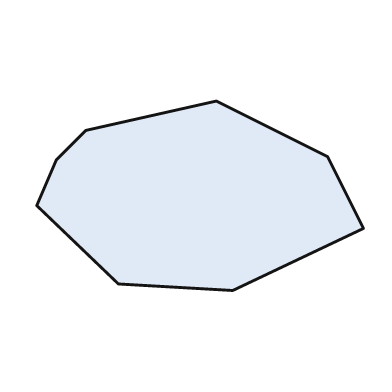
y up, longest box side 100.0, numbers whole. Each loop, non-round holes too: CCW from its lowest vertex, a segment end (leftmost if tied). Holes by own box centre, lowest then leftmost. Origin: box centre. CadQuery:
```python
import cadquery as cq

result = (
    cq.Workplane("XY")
    .moveTo(10.0, -29.0)
    .lineTo(50.0, -10.0)
    .lineTo(39.0, 12.0)
    .lineTo(5.0, 29.0)
    .lineTo(-35.0, 20.0)
    .lineTo(-44.0, 11.0)
    .lineTo(-50.0, -3.0)
    .lineTo(-25.0, -27.0)
    .close()
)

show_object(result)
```